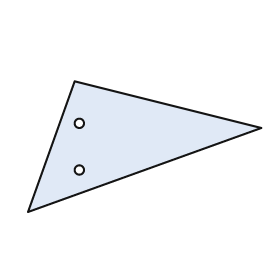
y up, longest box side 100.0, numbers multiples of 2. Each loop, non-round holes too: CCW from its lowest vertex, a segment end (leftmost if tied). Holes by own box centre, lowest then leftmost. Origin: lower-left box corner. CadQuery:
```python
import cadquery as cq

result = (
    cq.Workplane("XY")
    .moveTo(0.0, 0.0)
    .lineTo(100.0, 36.0)
    .lineTo(20.0, 56.0)
    .close()
    .moveTo(22.0, 18.0)
    .circle(2.0)
    .moveTo(22.0, 38.0)
    .circle(2.0)
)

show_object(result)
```